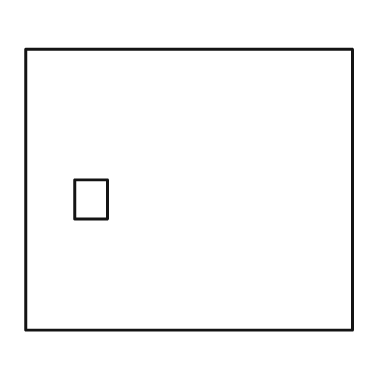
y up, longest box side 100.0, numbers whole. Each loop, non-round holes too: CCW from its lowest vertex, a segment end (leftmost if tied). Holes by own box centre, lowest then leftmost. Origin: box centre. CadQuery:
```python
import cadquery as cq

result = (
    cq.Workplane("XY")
    .moveTo(-50.0, -43.0)
    .lineTo(50.0, -43.0)
    .lineTo(50.0, 43.0)
    .lineTo(-50.0, 43.0)
    .close()
    .moveTo(-35.0, -9.0)
    .lineTo(-25.0, -9.0)
    .lineTo(-25.0, 3.0)
    .lineTo(-35.0, 3.0)
    .close()
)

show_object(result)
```